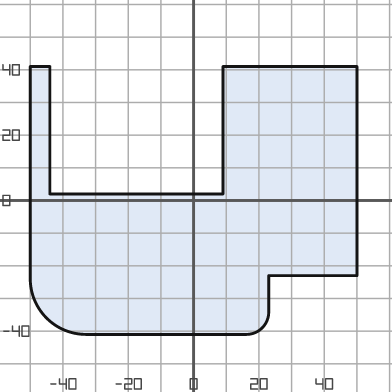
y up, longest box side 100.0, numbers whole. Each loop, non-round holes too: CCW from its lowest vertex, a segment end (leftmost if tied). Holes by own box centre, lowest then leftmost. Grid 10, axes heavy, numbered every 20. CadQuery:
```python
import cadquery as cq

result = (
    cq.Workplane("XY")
    .moveTo(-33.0, -41.0)
    .lineTo(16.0, -41.0)
    .threePointArc((21.0, -39.0), (23.0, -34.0))
    .lineTo(23.0, -23.0)
    .lineTo(50.0, -23.0)
    .lineTo(50.0, 41.0)
    .lineTo(9.0, 41.0)
    .lineTo(9.0, 2.0)
    .lineTo(-44.0, 2.0)
    .lineTo(-44.0, 41.0)
    .lineTo(-50.0, 41.0)
    .lineTo(-50.0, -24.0)
    .threePointArc((-45.0, -36.0), (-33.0, -41.0))
    .close()
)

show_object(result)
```